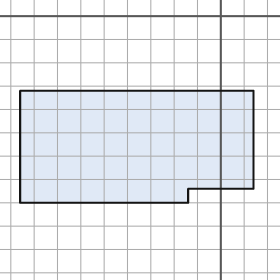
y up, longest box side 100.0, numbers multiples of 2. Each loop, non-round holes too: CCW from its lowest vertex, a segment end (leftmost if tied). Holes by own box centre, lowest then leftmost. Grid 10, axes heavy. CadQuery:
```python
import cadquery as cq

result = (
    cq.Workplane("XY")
    .moveTo(-86.0, -80.0)
    .lineTo(-14.0, -80.0)
    .lineTo(-14.0, -74.0)
    .lineTo(14.0, -74.0)
    .lineTo(14.0, -32.0)
    .lineTo(-86.0, -32.0)
    .close()
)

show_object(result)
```